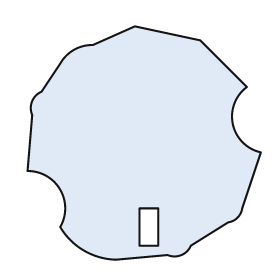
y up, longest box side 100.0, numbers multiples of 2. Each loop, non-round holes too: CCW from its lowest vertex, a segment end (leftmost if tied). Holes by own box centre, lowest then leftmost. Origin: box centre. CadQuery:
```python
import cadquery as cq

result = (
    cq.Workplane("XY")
    .moveTo(-12.0, -50.0)
    .lineTo(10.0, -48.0)
    .threePointArc((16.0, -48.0), (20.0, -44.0))
    .lineTo(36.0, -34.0)
    .threePointArc((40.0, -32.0), (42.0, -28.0))
    .lineTo(50.0, -4.0)
    .threePointArc((38.0, 8.0), (44.0, 24.0))
    .lineTo(24.0, 44.0)
    .lineTo(-4.0, 50.0)
    .lineTo(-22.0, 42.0)
    .threePointArc((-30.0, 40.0), (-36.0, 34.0))
    .lineTo(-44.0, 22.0)
    .threePointArc((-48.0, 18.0), (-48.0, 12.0))
    .lineTo(-50.0, -12.0)
    .threePointArc((-36.0, -20.0), (-36.0, -36.0))
    .threePointArc((-26.0, -46.0), (-12.0, -50.0))
    .close()
    .moveTo(-2.0, -44.0)
    .lineTo(6.0, -44.0)
    .lineTo(6.0, -28.0)
    .lineTo(-2.0, -28.0)
    .close()
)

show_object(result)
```